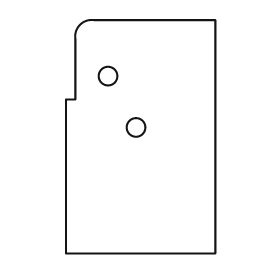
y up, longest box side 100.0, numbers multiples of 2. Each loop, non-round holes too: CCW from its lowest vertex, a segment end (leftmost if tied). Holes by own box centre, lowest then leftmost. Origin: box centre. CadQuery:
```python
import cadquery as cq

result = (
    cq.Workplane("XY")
    .moveTo(-32.0, -50.0)
    .lineTo(32.0, -50.0)
    .lineTo(32.0, 50.0)
    .lineTo(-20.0, 50.0)
    .threePointArc((-26.0, 48.0), (-28.0, 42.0))
    .lineTo(-28.0, 16.0)
    .lineTo(-32.0, 16.0)
    .close()
    .moveTo(-2.0, 4.0)
    .circle(4.0)
    .moveTo(-14.0, 26.0)
    .circle(4.0)
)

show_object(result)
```